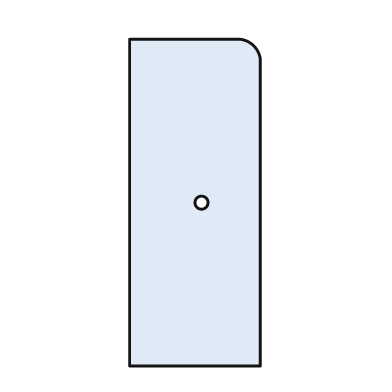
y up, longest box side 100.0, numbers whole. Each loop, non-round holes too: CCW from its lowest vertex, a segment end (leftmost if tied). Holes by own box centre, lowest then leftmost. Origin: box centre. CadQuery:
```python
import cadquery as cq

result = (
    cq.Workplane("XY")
    .moveTo(-20.0, -50.0)
    .lineTo(20.0, -50.0)
    .lineTo(20.0, 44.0)
    .threePointArc((18.0, 48.0), (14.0, 50.0))
    .lineTo(-20.0, 50.0)
    .close()
    .moveTo(2.0, 0.0)
    .circle(2.0)
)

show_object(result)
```